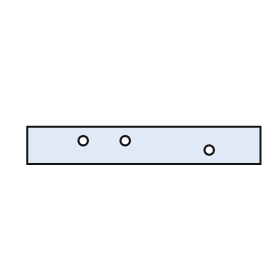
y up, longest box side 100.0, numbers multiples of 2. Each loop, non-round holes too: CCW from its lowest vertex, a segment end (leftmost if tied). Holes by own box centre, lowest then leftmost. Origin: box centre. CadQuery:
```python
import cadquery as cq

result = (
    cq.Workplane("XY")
    .moveTo(-50.0, -8.0)
    .lineTo(50.0, -8.0)
    .lineTo(50.0, 8.0)
    .lineTo(-50.0, 8.0)
    .close()
    .moveTo(28.0, -2.0)
    .circle(2.0)
    .moveTo(-26.0, 2.0)
    .circle(2.0)
    .moveTo(-8.0, 2.0)
    .circle(2.0)
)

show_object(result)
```